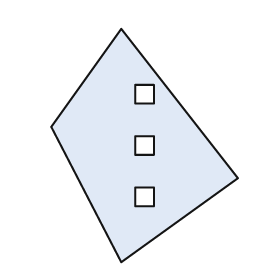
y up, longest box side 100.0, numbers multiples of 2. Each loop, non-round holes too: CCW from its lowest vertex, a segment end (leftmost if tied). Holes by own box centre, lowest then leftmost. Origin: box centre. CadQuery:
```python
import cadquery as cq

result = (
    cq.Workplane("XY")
    .moveTo(-10.0, -50.0)
    .lineTo(40.0, -14.0)
    .lineTo(-10.0, 50.0)
    .lineTo(-40.0, 8.0)
    .close()
    .moveTo(-4.0, -26.0)
    .lineTo(4.0, -26.0)
    .lineTo(4.0, -18.0)
    .lineTo(-4.0, -18.0)
    .close()
    .moveTo(-4.0, -4.0)
    .lineTo(4.0, -4.0)
    .lineTo(4.0, 4.0)
    .lineTo(-4.0, 4.0)
    .close()
    .moveTo(-4.0, 18.0)
    .lineTo(4.0, 18.0)
    .lineTo(4.0, 26.0)
    .lineTo(-4.0, 26.0)
    .close()
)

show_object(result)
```